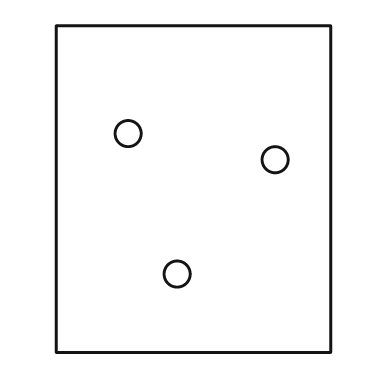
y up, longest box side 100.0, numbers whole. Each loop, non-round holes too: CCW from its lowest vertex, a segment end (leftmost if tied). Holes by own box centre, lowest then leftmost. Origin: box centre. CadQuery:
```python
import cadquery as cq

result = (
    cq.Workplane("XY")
    .moveTo(-42.0, -50.0)
    .lineTo(42.0, -50.0)
    .lineTo(42.0, 50.0)
    .lineTo(-42.0, 50.0)
    .close()
    .moveTo(-5.0, -26.0)
    .circle(4.0)
    .moveTo(25.0, 9.0)
    .circle(4.0)
    .moveTo(-20.0, 17.0)
    .circle(4.0)
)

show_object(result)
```